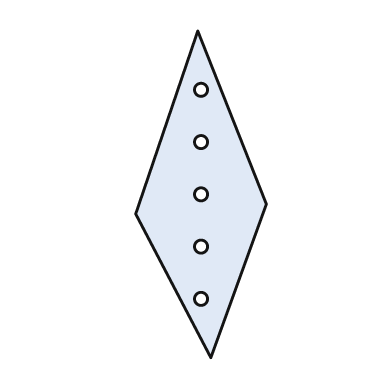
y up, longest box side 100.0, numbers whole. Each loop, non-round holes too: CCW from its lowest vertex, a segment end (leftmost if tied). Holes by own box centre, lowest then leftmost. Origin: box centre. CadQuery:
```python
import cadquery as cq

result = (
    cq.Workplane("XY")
    .moveTo(3.0, -50.0)
    .lineTo(20.0, -3.0)
    .lineTo(-1.0, 50.0)
    .lineTo(-20.0, -6.0)
    .close()
    .moveTo(0.0, -32.0)
    .circle(2.0)
    .moveTo(0.0, -16.0)
    .circle(2.0)
    .moveTo(0.0, 0.0)
    .circle(2.0)
    .moveTo(0.0, 16.0)
    .circle(2.0)
    .moveTo(0.0, 32.0)
    .circle(2.0)
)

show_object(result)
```